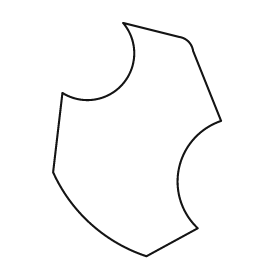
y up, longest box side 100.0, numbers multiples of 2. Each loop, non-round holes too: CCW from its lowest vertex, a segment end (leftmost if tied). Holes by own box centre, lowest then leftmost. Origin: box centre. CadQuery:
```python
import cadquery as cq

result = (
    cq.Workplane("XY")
    .moveTo(4.0, -50.0)
    .lineTo(26.0, -38.0)
    .threePointArc((18.0, -12.0), (36.0, 8.0))
    .lineTo(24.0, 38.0)
    .threePointArc((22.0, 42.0), (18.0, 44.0))
    .lineTo(-6.0, 50.0)
    .threePointArc((-6.0, 24.0), (-32.0, 20.0))
    .lineTo(-36.0, -14.0)
    .threePointArc((-20.0, -36.0), (4.0, -50.0))
    .close()
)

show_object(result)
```